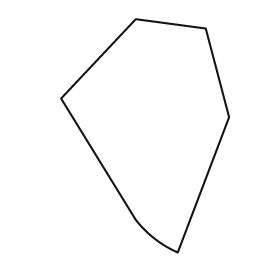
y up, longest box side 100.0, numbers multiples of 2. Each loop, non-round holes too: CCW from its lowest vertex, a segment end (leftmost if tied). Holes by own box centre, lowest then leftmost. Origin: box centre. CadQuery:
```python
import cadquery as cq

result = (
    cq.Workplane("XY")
    .moveTo(14.0, -50.0)
    .lineTo(36.0, 8.0)
    .lineTo(26.0, 46.0)
    .lineTo(-4.0, 50.0)
    .lineTo(-36.0, 16.0)
    .lineTo(-4.0, -36.0)
    .threePointArc((4.0, -44.0), (14.0, -50.0))
    .close()
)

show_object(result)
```